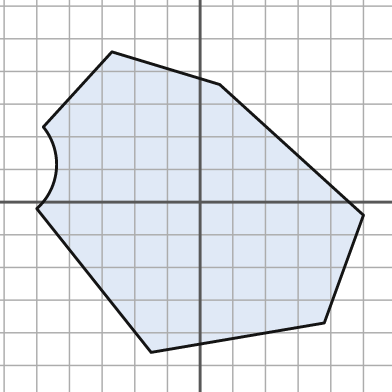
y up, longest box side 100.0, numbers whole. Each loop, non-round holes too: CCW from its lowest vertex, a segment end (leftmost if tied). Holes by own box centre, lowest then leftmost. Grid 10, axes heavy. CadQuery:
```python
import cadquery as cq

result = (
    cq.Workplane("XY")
    .moveTo(-15.0, -46.0)
    .lineTo(38.0, -37.0)
    .lineTo(50.0, -4.0)
    .lineTo(6.0, 36.0)
    .lineTo(-27.0, 46.0)
    .lineTo(-48.0, 23.0)
    .threePointArc((-44.0, 10.0), (-50.0, -2.0))
    .close()
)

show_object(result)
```